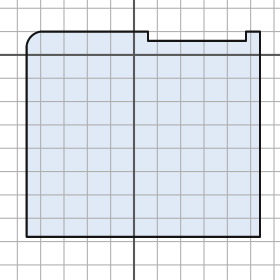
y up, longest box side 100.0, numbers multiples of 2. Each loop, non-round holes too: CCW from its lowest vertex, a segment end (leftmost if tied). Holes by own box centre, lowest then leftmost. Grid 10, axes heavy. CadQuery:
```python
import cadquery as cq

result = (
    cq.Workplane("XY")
    .moveTo(-46.0, -78.0)
    .lineTo(54.0, -78.0)
    .lineTo(54.0, 10.0)
    .lineTo(48.0, 10.0)
    .lineTo(48.0, 6.0)
    .lineTo(6.0, 6.0)
    .lineTo(6.0, 10.0)
    .lineTo(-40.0, 10.0)
    .threePointArc((-44.0, 8.0), (-46.0, 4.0))
    .close()
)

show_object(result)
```